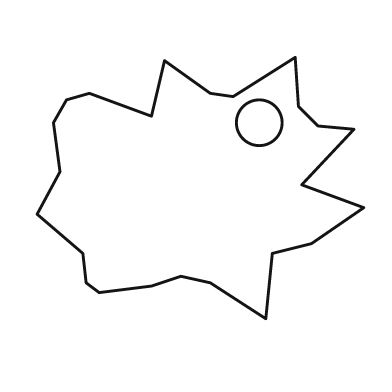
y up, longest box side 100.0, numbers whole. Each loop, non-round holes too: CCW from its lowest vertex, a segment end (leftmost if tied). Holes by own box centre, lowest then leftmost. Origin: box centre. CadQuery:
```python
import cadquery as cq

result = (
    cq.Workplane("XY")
    .moveTo(20.0, -40.0)
    .lineTo(22.0, -20.0)
    .lineTo(34.0, -17.0)
    .lineTo(50.0, -6.0)
    .lineTo(31.0, 1.0)
    .lineTo(47.0, 18.0)
    .lineTo(36.0, 19.0)
    .lineTo(30.0, 25.0)
    .lineTo(29.0, 40.0)
    .lineTo(10.0, 28.0)
    .lineTo(3.0, 29.0)
    .lineTo(-11.0, 39.0)
    .lineTo(-15.0, 22.0)
    .lineTo(-34.0, 29.0)
    .lineTo(-41.0, 27.0)
    .lineTo(-45.0, 20.0)
    .lineTo(-43.0, 5.0)
    .lineTo(-50.0, -8.0)
    .lineTo(-36.0, -20.0)
    .lineTo(-35.0, -29.0)
    .lineTo(-31.0, -32.0)
    .lineTo(-15.0, -30.0)
    .lineTo(-6.0, -27.0)
    .lineTo(3.0, -29.0)
    .close()
    .moveTo(18.0, 20.0)
    .circle(7.0)
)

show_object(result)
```